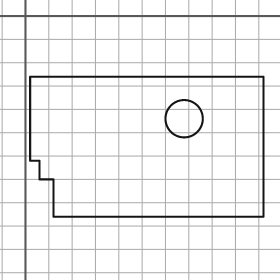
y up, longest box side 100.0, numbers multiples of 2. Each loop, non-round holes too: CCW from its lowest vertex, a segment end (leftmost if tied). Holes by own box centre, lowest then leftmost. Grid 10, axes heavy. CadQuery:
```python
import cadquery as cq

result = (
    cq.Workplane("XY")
    .moveTo(12.0, -86.0)
    .lineTo(102.0, -86.0)
    .lineTo(102.0, -26.0)
    .lineTo(2.0, -26.0)
    .lineTo(2.0, -62.0)
    .lineTo(6.0, -62.0)
    .lineTo(6.0, -70.0)
    .lineTo(12.0, -70.0)
    .close()
    .moveTo(68.0, -44.0)
    .circle(8.0)
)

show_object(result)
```